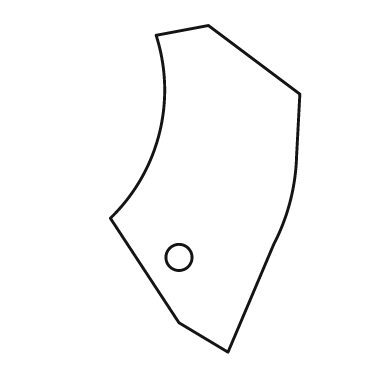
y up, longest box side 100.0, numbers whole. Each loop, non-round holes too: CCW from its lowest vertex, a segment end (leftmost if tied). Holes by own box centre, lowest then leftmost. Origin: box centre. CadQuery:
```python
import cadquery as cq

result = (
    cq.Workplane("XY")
    .moveTo(7.0, -50.0)
    .lineTo(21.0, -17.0)
    .threePointArc((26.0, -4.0), (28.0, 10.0))
    .lineTo(29.0, 29.0)
    .lineTo(1.0, 50.0)
    .lineTo(-15.0, 47.0)
    .threePointArc((-14.0, 17.0), (-29.0, -9.0))
    .lineTo(-8.0, -41.0)
    .close()
    .moveTo(-8.0, -21.0)
    .circle(4.0)
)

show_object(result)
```